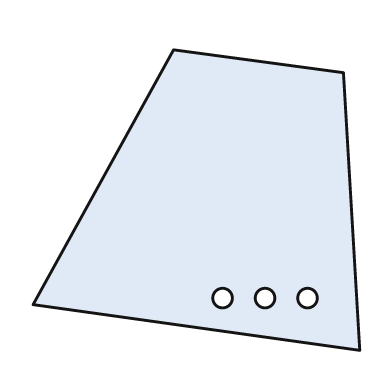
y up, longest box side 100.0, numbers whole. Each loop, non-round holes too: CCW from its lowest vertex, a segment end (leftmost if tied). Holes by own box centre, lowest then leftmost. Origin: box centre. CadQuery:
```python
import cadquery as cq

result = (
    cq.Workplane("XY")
    .moveTo(50.0, -46.0)
    .lineTo(45.0, 39.0)
    .lineTo(-7.0, 46.0)
    .lineTo(-50.0, -32.0)
    .close()
    .moveTo(8.0, -30.0)
    .circle(3.0)
    .moveTo(21.0, -30.0)
    .circle(3.0)
    .moveTo(34.0, -30.0)
    .circle(3.0)
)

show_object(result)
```